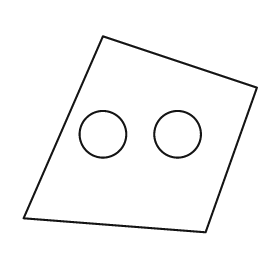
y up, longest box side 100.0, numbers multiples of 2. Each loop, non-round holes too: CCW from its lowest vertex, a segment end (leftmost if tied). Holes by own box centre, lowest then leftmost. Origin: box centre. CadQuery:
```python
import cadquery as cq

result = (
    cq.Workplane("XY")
    .moveTo(28.0, -42.0)
    .lineTo(50.0, 20.0)
    .lineTo(-16.0, 42.0)
    .lineTo(-50.0, -36.0)
    .close()
    .moveTo(-16.0, 0.0)
    .circle(10.0)
    .moveTo(16.0, 0.0)
    .circle(10.0)
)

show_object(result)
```